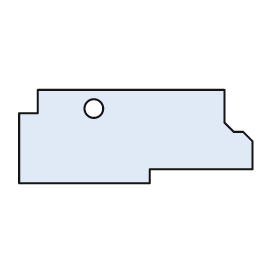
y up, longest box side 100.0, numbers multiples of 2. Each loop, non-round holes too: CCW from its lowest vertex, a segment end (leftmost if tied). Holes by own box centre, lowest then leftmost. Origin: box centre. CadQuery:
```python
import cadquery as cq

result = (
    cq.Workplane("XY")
    .moveTo(-50.0, -20.0)
    .lineTo(6.0, -20.0)
    .lineTo(6.0, -14.0)
    .lineTo(50.0, -14.0)
    .lineTo(50.0, -2.0)
    .lineTo(46.0, 2.0)
    .lineTo(42.0, 2.0)
    .lineTo(38.0, 6.0)
    .lineTo(38.0, 20.0)
    .lineTo(-42.0, 20.0)
    .lineTo(-42.0, 10.0)
    .lineTo(-50.0, 10.0)
    .close()
    .moveTo(-18.0, 12.0)
    .circle(4.0)
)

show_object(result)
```